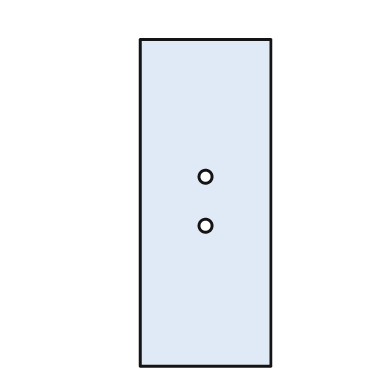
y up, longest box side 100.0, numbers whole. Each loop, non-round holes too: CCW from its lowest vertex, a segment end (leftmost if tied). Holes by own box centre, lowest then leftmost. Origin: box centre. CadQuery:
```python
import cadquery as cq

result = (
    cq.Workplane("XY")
    .moveTo(-20.0, -50.0)
    .lineTo(20.0, -50.0)
    .lineTo(20.0, 50.0)
    .lineTo(-20.0, 50.0)
    .close()
    .moveTo(0.0, -7.0)
    .circle(2.0)
    .moveTo(0.0, 8.0)
    .circle(2.0)
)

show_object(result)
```